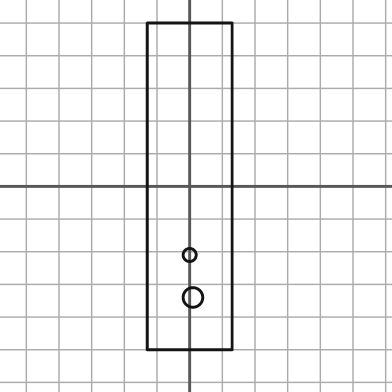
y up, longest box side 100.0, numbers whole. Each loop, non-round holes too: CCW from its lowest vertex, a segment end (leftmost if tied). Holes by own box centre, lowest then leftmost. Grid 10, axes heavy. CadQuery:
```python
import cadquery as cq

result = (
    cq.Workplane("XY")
    .moveTo(-13.0, -50.0)
    .lineTo(13.0, -50.0)
    .lineTo(13.0, 50.0)
    .lineTo(-13.0, 50.0)
    .close()
    .moveTo(1.0, -34.0)
    .circle(3.0)
    .moveTo(0.0, -21.0)
    .circle(2.0)
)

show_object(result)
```